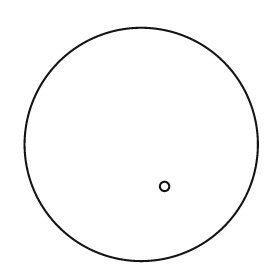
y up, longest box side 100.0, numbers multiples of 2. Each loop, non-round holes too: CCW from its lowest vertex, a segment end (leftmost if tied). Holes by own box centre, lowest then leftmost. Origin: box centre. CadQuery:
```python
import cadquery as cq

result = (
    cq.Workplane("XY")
    .moveTo(0.0, 0.0)
    .circle(50.0)
    .moveTo(10.0, -18.0)
    .circle(2.0)
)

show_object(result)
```